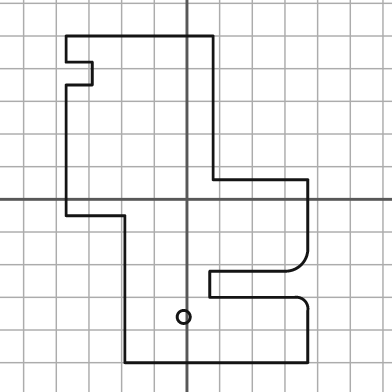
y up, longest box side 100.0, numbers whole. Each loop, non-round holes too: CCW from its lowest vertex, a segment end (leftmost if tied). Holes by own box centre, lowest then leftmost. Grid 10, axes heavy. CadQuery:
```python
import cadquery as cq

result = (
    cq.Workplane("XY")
    .moveTo(-19.0, -50.0)
    .lineTo(37.0, -50.0)
    .lineTo(37.0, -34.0)
    .threePointArc((36.0, -31.0), (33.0, -30.0))
    .lineTo(7.0, -30.0)
    .lineTo(7.0, -22.0)
    .lineTo(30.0, -22.0)
    .threePointArc((35.0, -20.0), (37.0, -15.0))
    .lineTo(37.0, 6.0)
    .lineTo(8.0, 6.0)
    .lineTo(8.0, 50.0)
    .lineTo(-37.0, 50.0)
    .lineTo(-37.0, 42.0)
    .lineTo(-29.0, 42.0)
    .lineTo(-29.0, 35.0)
    .lineTo(-37.0, 35.0)
    .lineTo(-37.0, -5.0)
    .lineTo(-19.0, -5.0)
    .close()
    .moveTo(-1.0, -36.0)
    .circle(2.0)
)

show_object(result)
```